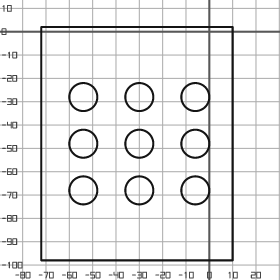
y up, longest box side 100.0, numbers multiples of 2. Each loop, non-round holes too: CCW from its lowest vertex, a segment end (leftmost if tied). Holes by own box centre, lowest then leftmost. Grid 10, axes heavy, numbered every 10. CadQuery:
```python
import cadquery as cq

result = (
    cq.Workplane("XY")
    .moveTo(-72.0, -98.0)
    .lineTo(10.0, -98.0)
    .lineTo(10.0, 2.0)
    .lineTo(-72.0, 2.0)
    .close()
    .moveTo(-54.0, -68.0)
    .circle(6.0)
    .moveTo(-30.0, -68.0)
    .circle(6.0)
    .moveTo(-6.0, -68.0)
    .circle(6.0)
    .moveTo(-54.0, -48.0)
    .circle(6.0)
    .moveTo(-30.0, -48.0)
    .circle(6.0)
    .moveTo(-6.0, -48.0)
    .circle(6.0)
    .moveTo(-54.0, -28.0)
    .circle(6.0)
    .moveTo(-30.0, -28.0)
    .circle(6.0)
    .moveTo(-6.0, -28.0)
    .circle(6.0)
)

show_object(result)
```